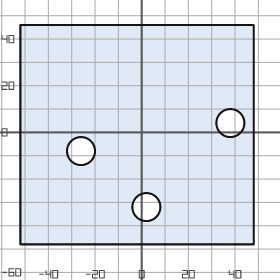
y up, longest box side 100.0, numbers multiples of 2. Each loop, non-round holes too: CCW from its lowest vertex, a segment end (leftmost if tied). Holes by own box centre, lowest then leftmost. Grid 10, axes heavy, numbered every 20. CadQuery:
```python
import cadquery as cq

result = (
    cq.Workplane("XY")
    .moveTo(-52.0, -48.0)
    .lineTo(48.0, -48.0)
    .lineTo(48.0, 46.0)
    .lineTo(-52.0, 46.0)
    .close()
    .moveTo(2.0, -32.0)
    .circle(6.0)
    .moveTo(-26.0, -8.0)
    .circle(6.0)
    .moveTo(38.0, 4.0)
    .circle(6.0)
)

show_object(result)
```